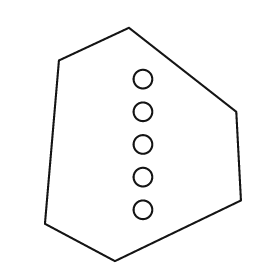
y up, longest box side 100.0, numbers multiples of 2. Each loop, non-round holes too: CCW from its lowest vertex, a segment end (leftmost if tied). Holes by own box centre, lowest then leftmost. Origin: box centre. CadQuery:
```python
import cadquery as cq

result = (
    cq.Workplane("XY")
    .moveTo(-12.0, -50.0)
    .lineTo(42.0, -24.0)
    .lineTo(40.0, 14.0)
    .lineTo(-6.0, 50.0)
    .lineTo(-36.0, 36.0)
    .lineTo(-42.0, -34.0)
    .close()
    .moveTo(0.0, -28.0)
    .circle(4.0)
    .moveTo(0.0, -14.0)
    .circle(4.0)
    .moveTo(0.0, 0.0)
    .circle(4.0)
    .moveTo(0.0, 14.0)
    .circle(4.0)
    .moveTo(0.0, 28.0)
    .circle(4.0)
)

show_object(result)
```